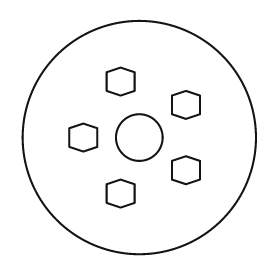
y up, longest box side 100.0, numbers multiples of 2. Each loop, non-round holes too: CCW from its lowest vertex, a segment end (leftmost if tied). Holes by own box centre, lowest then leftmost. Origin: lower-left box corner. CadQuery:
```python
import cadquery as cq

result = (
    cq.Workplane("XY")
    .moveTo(50.0, 50.0)
    .circle(50.0)
    .moveTo(42.0, 20.0)
    .lineTo(48.0, 22.0)
    .lineTo(48.0, 30.0)
    .lineTo(42.0, 32.0)
    .lineTo(36.0, 30.0)
    .lineTo(36.0, 22.0)
    .close()
    .moveTo(70.0, 30.0)
    .lineTo(76.0, 32.0)
    .lineTo(76.0, 40.0)
    .lineTo(70.0, 42.0)
    .lineTo(64.0, 40.0)
    .lineTo(64.0, 32.0)
    .close()
    .moveTo(26.0, 44.0)
    .lineTo(32.0, 46.0)
    .lineTo(32.0, 54.0)
    .lineTo(26.0, 56.0)
    .lineTo(20.0, 54.0)
    .lineTo(20.0, 46.0)
    .close()
    .moveTo(50.0, 50.0)
    .circle(10.0)
    .moveTo(70.0, 58.0)
    .lineTo(76.0, 60.0)
    .lineTo(76.0, 68.0)
    .lineTo(70.0, 70.0)
    .lineTo(64.0, 68.0)
    .lineTo(64.0, 60.0)
    .close()
    .moveTo(42.0, 68.0)
    .lineTo(48.0, 70.0)
    .lineTo(48.0, 78.0)
    .lineTo(42.0, 80.0)
    .lineTo(36.0, 78.0)
    .lineTo(36.0, 70.0)
    .close()
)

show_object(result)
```